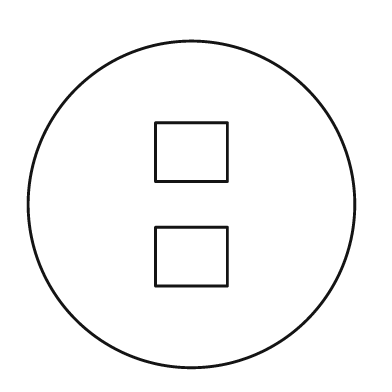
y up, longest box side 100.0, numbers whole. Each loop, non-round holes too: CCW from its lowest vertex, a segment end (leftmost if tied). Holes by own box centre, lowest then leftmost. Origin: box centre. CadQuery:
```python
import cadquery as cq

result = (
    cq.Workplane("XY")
    .moveTo(0.0, 0.0)
    .circle(50.0)
    .moveTo(-11.0, -25.0)
    .lineTo(11.0, -25.0)
    .lineTo(11.0, -7.0)
    .lineTo(-11.0, -7.0)
    .close()
    .moveTo(-11.0, 7.0)
    .lineTo(11.0, 7.0)
    .lineTo(11.0, 25.0)
    .lineTo(-11.0, 25.0)
    .close()
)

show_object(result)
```